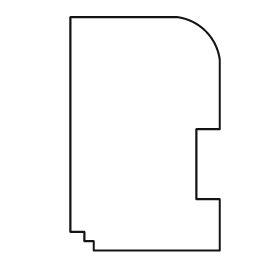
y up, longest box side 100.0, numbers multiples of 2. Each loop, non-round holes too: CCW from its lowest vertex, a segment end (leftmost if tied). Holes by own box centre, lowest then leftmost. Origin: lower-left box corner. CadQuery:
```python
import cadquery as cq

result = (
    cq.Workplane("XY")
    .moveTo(10.0, 0.0)
    .lineTo(64.0, 0.0)
    .lineTo(64.0, 22.0)
    .lineTo(54.0, 22.0)
    .lineTo(54.0, 52.0)
    .lineTo(64.0, 52.0)
    .lineTo(64.0, 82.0)
    .threePointArc((58.0, 94.0), (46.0, 100.0))
    .lineTo(0.0, 100.0)
    .lineTo(0.0, 8.0)
    .lineTo(6.0, 8.0)
    .lineTo(6.0, 4.0)
    .lineTo(10.0, 4.0)
    .close()
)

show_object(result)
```